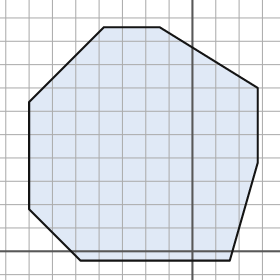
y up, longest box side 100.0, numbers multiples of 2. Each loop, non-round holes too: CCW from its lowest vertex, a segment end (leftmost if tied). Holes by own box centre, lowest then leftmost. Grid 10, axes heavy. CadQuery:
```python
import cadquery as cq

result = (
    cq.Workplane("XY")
    .moveTo(-48.0, -4.0)
    .lineTo(16.0, -4.0)
    .lineTo(28.0, 38.0)
    .lineTo(28.0, 70.0)
    .lineTo(-14.0, 96.0)
    .lineTo(-38.0, 96.0)
    .lineTo(-70.0, 64.0)
    .lineTo(-70.0, 18.0)
    .close()
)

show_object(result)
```